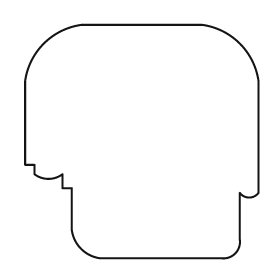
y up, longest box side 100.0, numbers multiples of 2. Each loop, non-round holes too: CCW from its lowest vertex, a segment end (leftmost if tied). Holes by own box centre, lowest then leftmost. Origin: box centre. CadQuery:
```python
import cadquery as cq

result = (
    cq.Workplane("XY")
    .moveTo(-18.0, -50.0)
    .lineTo(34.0, -50.0)
    .threePointArc((40.0, -48.0), (42.0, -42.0))
    .lineTo(42.0, -22.0)
    .threePointArc((46.0, -24.0), (50.0, -22.0))
    .lineTo(50.0, 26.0)
    .threePointArc((42.0, 42.0), (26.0, 50.0))
    .lineTo(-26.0, 50.0)
    .threePointArc((-42.0, 42.0), (-50.0, 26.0))
    .lineTo(-50.0, -10.0)
    .lineTo(-46.0, -10.0)
    .lineTo(-46.0, -14.0)
    .threePointArc((-40.0, -16.0), (-34.0, -14.0))
    .lineTo(-34.0, -20.0)
    .lineTo(-30.0, -20.0)
    .lineTo(-30.0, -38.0)
    .threePointArc((-26.0, -46.0), (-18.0, -50.0))
    .close()
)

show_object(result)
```